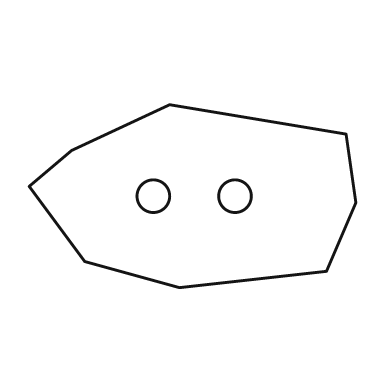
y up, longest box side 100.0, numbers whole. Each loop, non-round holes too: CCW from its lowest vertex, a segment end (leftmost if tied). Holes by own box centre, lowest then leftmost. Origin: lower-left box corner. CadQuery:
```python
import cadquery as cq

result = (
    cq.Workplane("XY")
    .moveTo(46.0, 0.0)
    .lineTo(91.0, 5.0)
    .lineTo(100.0, 26.0)
    .lineTo(97.0, 47.0)
    .lineTo(43.0, 56.0)
    .lineTo(13.0, 42.0)
    .lineTo(0.0, 31.0)
    .lineTo(17.0, 8.0)
    .close()
    .moveTo(38.0, 28.0)
    .circle(5.0)
    .moveTo(63.0, 28.0)
    .circle(5.0)
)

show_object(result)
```